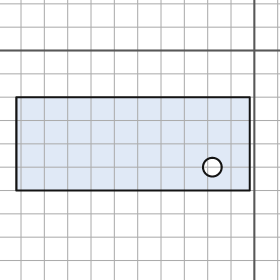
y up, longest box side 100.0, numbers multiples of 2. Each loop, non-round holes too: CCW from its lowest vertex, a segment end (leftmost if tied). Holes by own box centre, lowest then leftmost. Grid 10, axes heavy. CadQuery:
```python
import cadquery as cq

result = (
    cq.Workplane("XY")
    .moveTo(-102.0, -60.0)
    .lineTo(-2.0, -60.0)
    .lineTo(-2.0, -20.0)
    .lineTo(-102.0, -20.0)
    .close()
    .moveTo(-18.0, -50.0)
    .circle(4.0)
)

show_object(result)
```